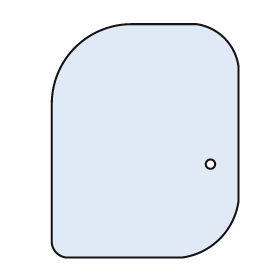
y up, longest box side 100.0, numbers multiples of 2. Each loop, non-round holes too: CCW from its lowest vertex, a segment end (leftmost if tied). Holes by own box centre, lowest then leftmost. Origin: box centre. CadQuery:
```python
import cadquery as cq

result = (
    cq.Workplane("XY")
    .moveTo(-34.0, -50.0)
    .lineTo(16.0, -50.0)
    .threePointArc((32.0, -42.0), (40.0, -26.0))
    .lineTo(40.0, 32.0)
    .threePointArc((34.0, 44.0), (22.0, 50.0))
    .lineTo(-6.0, 50.0)
    .threePointArc((-30.0, 40.0), (-40.0, 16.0))
    .lineTo(-40.0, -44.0)
    .threePointArc((-38.0, -48.0), (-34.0, -50.0))
    .close()
    .moveTo(28.0, -10.0)
    .circle(2.0)
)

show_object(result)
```